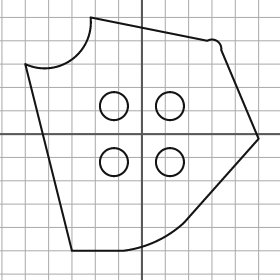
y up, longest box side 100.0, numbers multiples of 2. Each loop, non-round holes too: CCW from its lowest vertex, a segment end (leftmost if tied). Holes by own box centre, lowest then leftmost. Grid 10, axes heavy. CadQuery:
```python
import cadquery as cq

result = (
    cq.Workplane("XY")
    .moveTo(-30.0, -50.0)
    .lineTo(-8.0, -50.0)
    .threePointArc((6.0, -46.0), (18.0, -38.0))
    .lineTo(50.0, -2.0)
    .lineTo(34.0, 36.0)
    .threePointArc((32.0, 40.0), (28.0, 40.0))
    .lineTo(-22.0, 50.0)
    .threePointArc((-30.0, 32.0), (-50.0, 30.0))
    .close()
    .moveTo(-12.0, -12.0)
    .circle(6.0)
    .moveTo(12.0, -12.0)
    .circle(6.0)
    .moveTo(-12.0, 12.0)
    .circle(6.0)
    .moveTo(12.0, 12.0)
    .circle(6.0)
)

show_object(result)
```